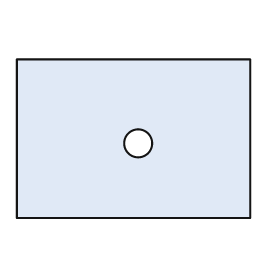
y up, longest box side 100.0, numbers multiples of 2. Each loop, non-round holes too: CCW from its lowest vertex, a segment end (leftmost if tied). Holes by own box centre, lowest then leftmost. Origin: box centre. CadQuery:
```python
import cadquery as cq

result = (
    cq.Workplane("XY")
    .moveTo(-50.0, -34.0)
    .lineTo(50.0, -34.0)
    .lineTo(50.0, 34.0)
    .lineTo(-50.0, 34.0)
    .close()
    .moveTo(2.0, -2.0)
    .circle(6.0)
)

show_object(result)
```